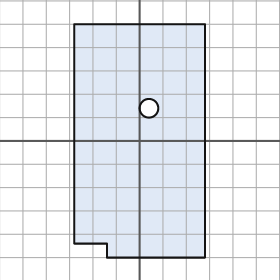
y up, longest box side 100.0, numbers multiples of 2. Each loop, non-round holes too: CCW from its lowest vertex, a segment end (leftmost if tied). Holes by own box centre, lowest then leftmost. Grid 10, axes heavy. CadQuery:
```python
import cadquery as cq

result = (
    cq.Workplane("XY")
    .moveTo(-14.0, -50.0)
    .lineTo(28.0, -50.0)
    .lineTo(28.0, 50.0)
    .lineTo(-28.0, 50.0)
    .lineTo(-28.0, -44.0)
    .lineTo(-14.0, -44.0)
    .close()
    .moveTo(4.0, 14.0)
    .circle(4.0)
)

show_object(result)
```